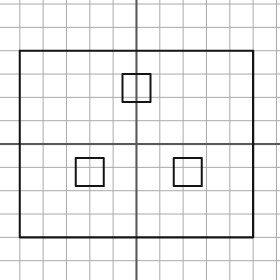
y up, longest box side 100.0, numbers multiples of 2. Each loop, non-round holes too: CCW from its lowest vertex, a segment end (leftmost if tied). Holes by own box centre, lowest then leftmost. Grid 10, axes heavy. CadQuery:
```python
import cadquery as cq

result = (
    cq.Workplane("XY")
    .moveTo(-50.0, -40.0)
    .lineTo(50.0, -40.0)
    .lineTo(50.0, 40.0)
    .lineTo(-50.0, 40.0)
    .close()
    .moveTo(-26.0, -18.0)
    .lineTo(-14.0, -18.0)
    .lineTo(-14.0, -6.0)
    .lineTo(-26.0, -6.0)
    .close()
    .moveTo(16.0, -18.0)
    .lineTo(28.0, -18.0)
    .lineTo(28.0, -6.0)
    .lineTo(16.0, -6.0)
    .close()
    .moveTo(-6.0, 18.0)
    .lineTo(6.0, 18.0)
    .lineTo(6.0, 30.0)
    .lineTo(-6.0, 30.0)
    .close()
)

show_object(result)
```